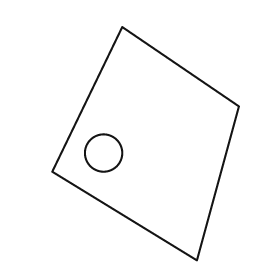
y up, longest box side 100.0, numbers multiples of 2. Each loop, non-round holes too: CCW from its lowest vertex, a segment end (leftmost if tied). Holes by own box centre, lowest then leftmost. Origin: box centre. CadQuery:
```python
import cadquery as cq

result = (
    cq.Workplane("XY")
    .moveTo(22.0, -50.0)
    .lineTo(40.0, 16.0)
    .lineTo(-10.0, 50.0)
    .lineTo(-40.0, -12.0)
    .close()
    .moveTo(-18.0, -4.0)
    .circle(8.0)
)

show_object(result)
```